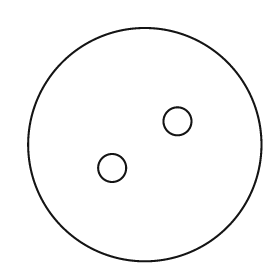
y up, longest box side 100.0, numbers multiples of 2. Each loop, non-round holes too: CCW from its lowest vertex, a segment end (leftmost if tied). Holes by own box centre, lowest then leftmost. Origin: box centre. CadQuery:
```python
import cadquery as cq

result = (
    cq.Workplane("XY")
    .moveTo(0.0, 0.0)
    .circle(50.0)
    .moveTo(-14.0, -10.0)
    .circle(6.0)
    .moveTo(14.0, 10.0)
    .circle(6.0)
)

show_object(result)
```